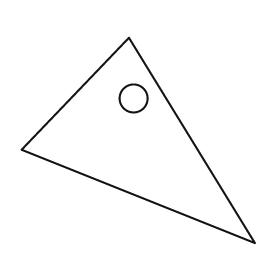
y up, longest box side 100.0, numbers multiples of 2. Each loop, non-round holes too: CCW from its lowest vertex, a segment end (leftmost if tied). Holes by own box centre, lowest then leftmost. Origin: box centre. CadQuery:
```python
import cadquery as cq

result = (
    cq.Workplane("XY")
    .moveTo(50.0, -44.0)
    .lineTo(-4.0, 44.0)
    .lineTo(-50.0, -4.0)
    .close()
    .moveTo(-2.0, 18.0)
    .circle(6.0)
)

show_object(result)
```